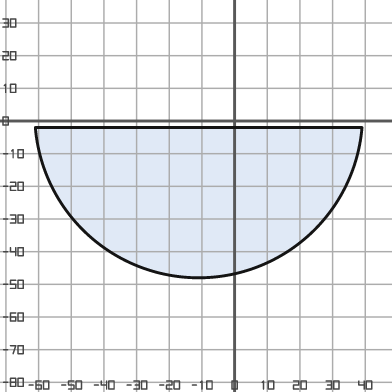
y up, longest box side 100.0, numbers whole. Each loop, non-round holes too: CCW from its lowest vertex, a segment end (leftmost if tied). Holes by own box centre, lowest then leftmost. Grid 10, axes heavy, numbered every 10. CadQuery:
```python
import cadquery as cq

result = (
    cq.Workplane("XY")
    .moveTo(-61.0, -2.0)
    .threePointArc((-11.0, -48.0), (39.0, -2.0))
    .close()
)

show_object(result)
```